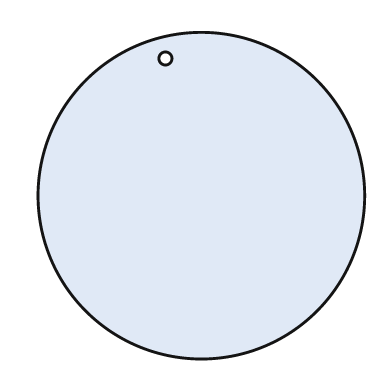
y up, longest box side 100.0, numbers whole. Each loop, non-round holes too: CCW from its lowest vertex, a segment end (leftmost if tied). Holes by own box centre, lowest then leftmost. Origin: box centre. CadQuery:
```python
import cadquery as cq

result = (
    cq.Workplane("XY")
    .moveTo(0.0, 0.0)
    .circle(50.0)
    .moveTo(-11.0, 42.0)
    .circle(2.0)
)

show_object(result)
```